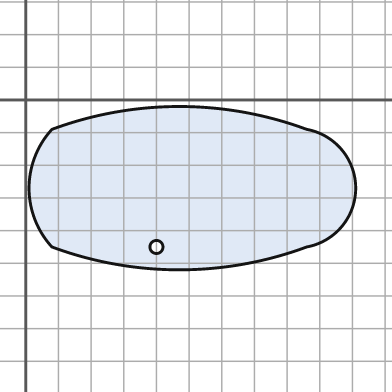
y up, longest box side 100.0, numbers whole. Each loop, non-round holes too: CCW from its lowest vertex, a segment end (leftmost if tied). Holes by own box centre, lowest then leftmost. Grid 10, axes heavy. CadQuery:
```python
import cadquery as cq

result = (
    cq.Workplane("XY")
    .moveTo(8.0, -45.0)
    .threePointArc((47.0, -52.0), (86.0, -45.0))
    .threePointArc((101.0, -27.0), (86.0, -9.0))
    .threePointArc((47.0, -2.0), (8.0, -9.0))
    .threePointArc((1.0, -27.0), (8.0, -45.0))
    .close()
    .moveTo(40.0, -45.0)
    .circle(2.0)
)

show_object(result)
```